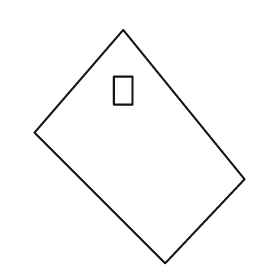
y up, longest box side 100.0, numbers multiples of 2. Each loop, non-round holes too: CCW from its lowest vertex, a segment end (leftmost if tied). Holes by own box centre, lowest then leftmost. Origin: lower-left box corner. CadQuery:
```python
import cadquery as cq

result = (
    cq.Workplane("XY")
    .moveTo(56.0, 0.0)
    .lineTo(90.0, 36.0)
    .lineTo(38.0, 100.0)
    .lineTo(0.0, 56.0)
    .close()
    .moveTo(34.0, 68.0)
    .lineTo(42.0, 68.0)
    .lineTo(42.0, 80.0)
    .lineTo(34.0, 80.0)
    .close()
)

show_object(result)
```